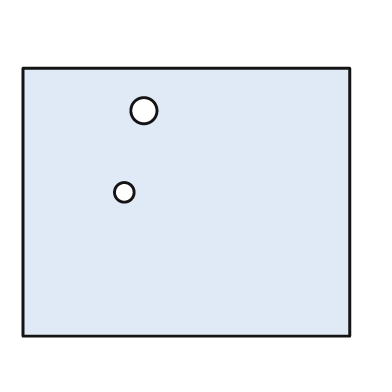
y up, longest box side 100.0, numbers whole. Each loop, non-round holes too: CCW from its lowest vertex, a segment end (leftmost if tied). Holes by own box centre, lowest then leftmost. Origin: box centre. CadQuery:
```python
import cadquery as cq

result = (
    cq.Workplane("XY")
    .moveTo(-50.0, -41.0)
    .lineTo(50.0, -41.0)
    .lineTo(50.0, 41.0)
    .lineTo(-50.0, 41.0)
    .close()
    .moveTo(-19.0, 3.0)
    .circle(3.0)
    .moveTo(-13.0, 28.0)
    .circle(4.0)
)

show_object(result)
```